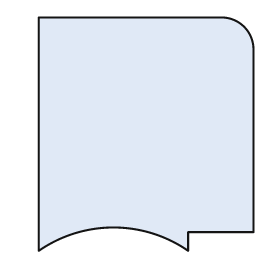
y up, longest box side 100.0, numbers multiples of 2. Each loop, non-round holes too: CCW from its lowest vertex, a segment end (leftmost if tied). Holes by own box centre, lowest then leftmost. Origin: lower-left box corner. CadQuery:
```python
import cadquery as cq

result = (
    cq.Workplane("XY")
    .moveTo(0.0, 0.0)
    .threePointArc((32.0, 10.0), (64.0, 0.0))
    .lineTo(64.0, 8.0)
    .lineTo(92.0, 8.0)
    .lineTo(92.0, 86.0)
    .threePointArc((88.0, 96.0), (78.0, 100.0))
    .lineTo(0.0, 100.0)
    .close()
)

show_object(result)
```